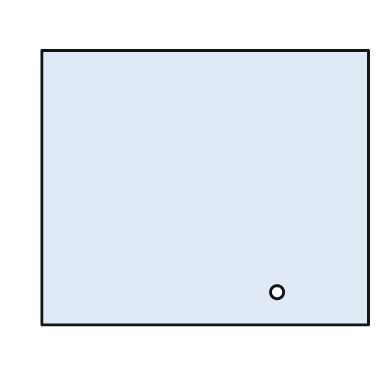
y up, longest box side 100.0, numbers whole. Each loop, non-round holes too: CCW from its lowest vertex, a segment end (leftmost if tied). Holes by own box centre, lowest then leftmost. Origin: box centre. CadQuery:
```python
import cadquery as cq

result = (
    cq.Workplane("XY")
    .moveTo(-50.0, -42.0)
    .lineTo(50.0, -42.0)
    .lineTo(50.0, 42.0)
    .lineTo(-50.0, 42.0)
    .close()
    .moveTo(22.0, -32.0)
    .circle(2.0)
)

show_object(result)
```